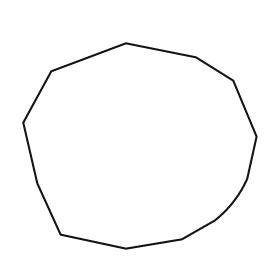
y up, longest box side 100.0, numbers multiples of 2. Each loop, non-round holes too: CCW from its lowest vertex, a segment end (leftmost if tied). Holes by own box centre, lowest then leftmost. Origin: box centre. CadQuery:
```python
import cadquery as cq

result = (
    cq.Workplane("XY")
    .moveTo(-6.0, -44.0)
    .lineTo(18.0, -40.0)
    .lineTo(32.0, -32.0)
    .threePointArc((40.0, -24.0), (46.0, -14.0))
    .lineTo(50.0, 4.0)
    .lineTo(40.0, 28.0)
    .lineTo(24.0, 38.0)
    .lineTo(-6.0, 44.0)
    .lineTo(-38.0, 32.0)
    .lineTo(-50.0, 10.0)
    .lineTo(-44.0, -16.0)
    .lineTo(-34.0, -38.0)
    .close()
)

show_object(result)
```